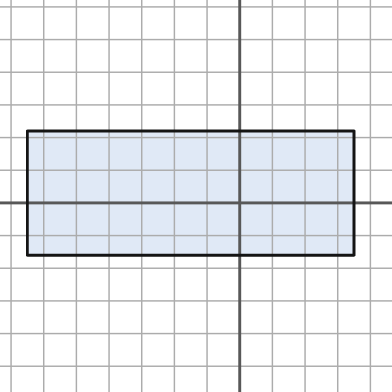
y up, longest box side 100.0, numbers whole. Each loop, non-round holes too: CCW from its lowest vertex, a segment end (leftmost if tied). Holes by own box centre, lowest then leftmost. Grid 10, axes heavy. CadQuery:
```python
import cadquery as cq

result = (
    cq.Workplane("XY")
    .moveTo(-65.0, -16.0)
    .lineTo(35.0, -16.0)
    .lineTo(35.0, 22.0)
    .lineTo(-65.0, 22.0)
    .close()
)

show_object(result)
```